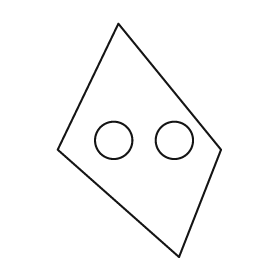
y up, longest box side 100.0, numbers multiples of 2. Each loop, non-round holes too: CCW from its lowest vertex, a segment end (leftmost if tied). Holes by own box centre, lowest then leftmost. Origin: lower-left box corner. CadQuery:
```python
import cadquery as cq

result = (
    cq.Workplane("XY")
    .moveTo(52.0, 0.0)
    .lineTo(70.0, 46.0)
    .lineTo(26.0, 100.0)
    .lineTo(0.0, 46.0)
    .close()
    .moveTo(24.0, 50.0)
    .circle(8.0)
    .moveTo(50.0, 50.0)
    .circle(8.0)
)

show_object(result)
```